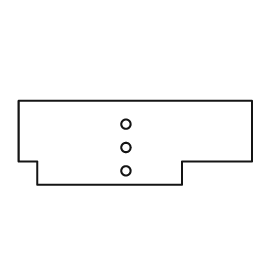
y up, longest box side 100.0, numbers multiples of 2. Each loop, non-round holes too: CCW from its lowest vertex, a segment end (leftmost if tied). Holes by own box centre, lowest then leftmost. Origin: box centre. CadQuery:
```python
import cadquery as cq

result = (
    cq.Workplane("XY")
    .moveTo(-42.0, -18.0)
    .lineTo(20.0, -18.0)
    .lineTo(20.0, -8.0)
    .lineTo(50.0, -8.0)
    .lineTo(50.0, 18.0)
    .lineTo(-50.0, 18.0)
    .lineTo(-50.0, -8.0)
    .lineTo(-42.0, -8.0)
    .close()
    .moveTo(-4.0, -12.0)
    .circle(2.0)
    .moveTo(-4.0, -2.0)
    .circle(2.0)
    .moveTo(-4.0, 8.0)
    .circle(2.0)
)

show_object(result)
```